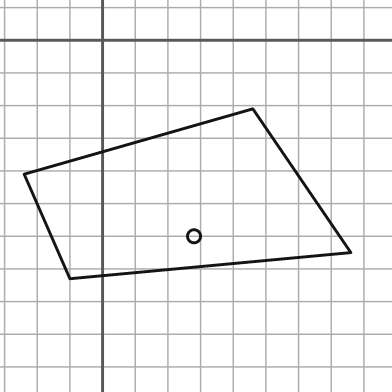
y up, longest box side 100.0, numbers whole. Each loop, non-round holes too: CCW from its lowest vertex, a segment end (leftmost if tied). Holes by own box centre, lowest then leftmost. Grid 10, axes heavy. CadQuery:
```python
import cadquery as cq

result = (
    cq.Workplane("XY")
    .moveTo(-10.0, -73.0)
    .lineTo(76.0, -65.0)
    .lineTo(46.0, -21.0)
    .lineTo(-24.0, -41.0)
    .close()
    .moveTo(28.0, -60.0)
    .circle(2.0)
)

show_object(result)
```